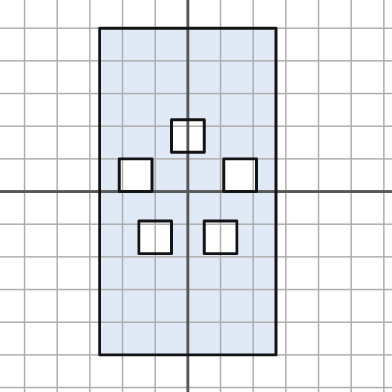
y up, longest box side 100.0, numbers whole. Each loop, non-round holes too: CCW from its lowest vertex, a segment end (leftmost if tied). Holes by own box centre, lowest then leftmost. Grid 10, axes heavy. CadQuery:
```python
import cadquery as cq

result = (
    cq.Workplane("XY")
    .moveTo(-27.0, -50.0)
    .lineTo(27.0, -50.0)
    .lineTo(27.0, 50.0)
    .lineTo(-27.0, 50.0)
    .close()
    .moveTo(-15.0, -19.0)
    .lineTo(-5.0, -19.0)
    .lineTo(-5.0, -9.0)
    .lineTo(-15.0, -9.0)
    .close()
    .moveTo(5.0, -19.0)
    .lineTo(15.0, -19.0)
    .lineTo(15.0, -9.0)
    .lineTo(5.0, -9.0)
    .close()
    .moveTo(-21.0, 0.0)
    .lineTo(-11.0, 0.0)
    .lineTo(-11.0, 10.0)
    .lineTo(-21.0, 10.0)
    .close()
    .moveTo(11.0, 0.0)
    .lineTo(21.0, 0.0)
    .lineTo(21.0, 10.0)
    .lineTo(11.0, 10.0)
    .close()
    .moveTo(-5.0, 12.0)
    .lineTo(5.0, 12.0)
    .lineTo(5.0, 22.0)
    .lineTo(-5.0, 22.0)
    .close()
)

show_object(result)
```